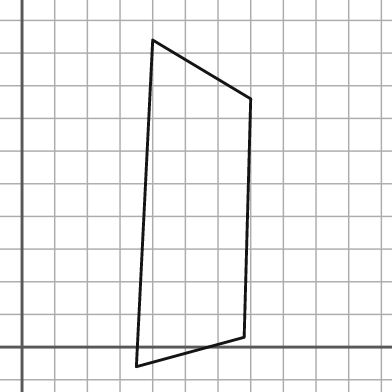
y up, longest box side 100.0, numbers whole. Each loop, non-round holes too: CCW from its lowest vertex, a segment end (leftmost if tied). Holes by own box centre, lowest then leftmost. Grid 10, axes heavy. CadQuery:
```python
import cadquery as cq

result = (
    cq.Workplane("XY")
    .moveTo(35.0, -6.0)
    .lineTo(68.0, 3.0)
    .lineTo(70.0, 76.0)
    .lineTo(40.0, 94.0)
    .close()
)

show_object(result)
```